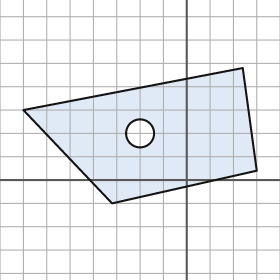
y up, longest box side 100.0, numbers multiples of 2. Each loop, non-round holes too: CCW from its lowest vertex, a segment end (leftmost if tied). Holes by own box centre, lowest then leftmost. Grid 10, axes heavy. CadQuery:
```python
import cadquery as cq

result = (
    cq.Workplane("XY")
    .moveTo(-32.0, -10.0)
    .lineTo(30.0, 4.0)
    .lineTo(24.0, 48.0)
    .lineTo(-70.0, 30.0)
    .close()
    .moveTo(-20.0, 20.0)
    .circle(6.0)
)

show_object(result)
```